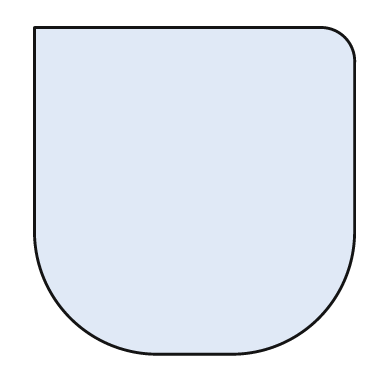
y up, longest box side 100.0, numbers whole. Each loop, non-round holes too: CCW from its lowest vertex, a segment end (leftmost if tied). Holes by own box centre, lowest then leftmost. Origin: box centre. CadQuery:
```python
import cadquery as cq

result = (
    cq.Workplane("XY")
    .moveTo(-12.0, -50.0)
    .lineTo(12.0, -50.0)
    .threePointArc((38.0, -39.0), (49.0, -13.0))
    .lineTo(49.0, 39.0)
    .threePointArc((46.0, 47.0), (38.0, 50.0))
    .lineTo(-49.0, 50.0)
    .lineTo(-49.0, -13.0)
    .threePointArc((-38.0, -39.0), (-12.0, -50.0))
    .close()
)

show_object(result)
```